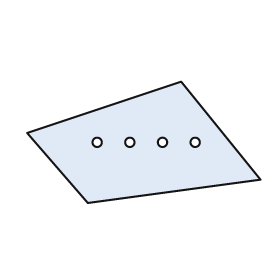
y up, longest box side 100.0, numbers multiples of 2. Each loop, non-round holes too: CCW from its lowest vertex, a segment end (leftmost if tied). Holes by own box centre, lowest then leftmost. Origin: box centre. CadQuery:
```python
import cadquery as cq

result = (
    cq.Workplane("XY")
    .moveTo(-24.0, -26.0)
    .lineTo(50.0, -16.0)
    .lineTo(16.0, 26.0)
    .lineTo(-50.0, 4.0)
    .close()
    .moveTo(-20.0, 0.0)
    .circle(2.0)
    .moveTo(-6.0, 0.0)
    .circle(2.0)
    .moveTo(8.0, 0.0)
    .circle(2.0)
    .moveTo(22.0, 0.0)
    .circle(2.0)
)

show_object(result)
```